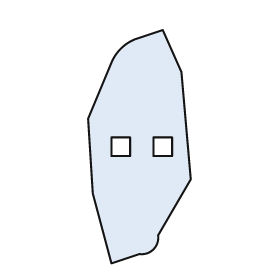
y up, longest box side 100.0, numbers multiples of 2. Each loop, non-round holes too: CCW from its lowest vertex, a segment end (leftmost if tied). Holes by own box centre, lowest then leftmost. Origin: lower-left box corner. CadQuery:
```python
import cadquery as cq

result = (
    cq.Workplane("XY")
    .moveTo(10.0, 0.0)
    .lineTo(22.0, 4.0)
    .threePointArc((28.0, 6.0), (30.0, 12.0))
    .lineTo(44.0, 36.0)
    .lineTo(40.0, 82.0)
    .lineTo(32.0, 100.0)
    .lineTo(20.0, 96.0)
    .threePointArc((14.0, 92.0), (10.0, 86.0))
    .lineTo(0.0, 62.0)
    .lineTo(2.0, 30.0)
    .close()
    .moveTo(10.0, 46.0)
    .lineTo(18.0, 46.0)
    .lineTo(18.0, 54.0)
    .lineTo(10.0, 54.0)
    .close()
    .moveTo(28.0, 46.0)
    .lineTo(36.0, 46.0)
    .lineTo(36.0, 54.0)
    .lineTo(28.0, 54.0)
    .close()
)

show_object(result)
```